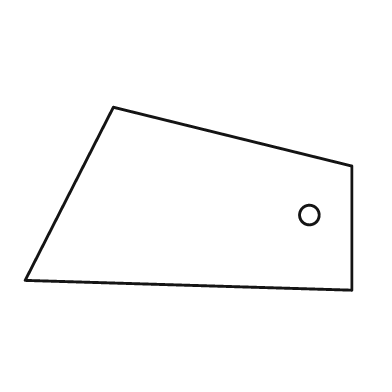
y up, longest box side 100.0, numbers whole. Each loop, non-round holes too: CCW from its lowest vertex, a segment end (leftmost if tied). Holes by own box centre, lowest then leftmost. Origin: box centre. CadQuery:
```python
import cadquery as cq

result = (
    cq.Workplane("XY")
    .moveTo(50.0, -28.0)
    .lineTo(50.0, 10.0)
    .lineTo(-23.0, 28.0)
    .lineTo(-50.0, -25.0)
    .close()
    .moveTo(37.0, -5.0)
    .circle(3.0)
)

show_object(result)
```